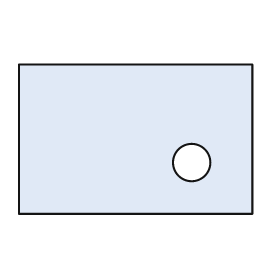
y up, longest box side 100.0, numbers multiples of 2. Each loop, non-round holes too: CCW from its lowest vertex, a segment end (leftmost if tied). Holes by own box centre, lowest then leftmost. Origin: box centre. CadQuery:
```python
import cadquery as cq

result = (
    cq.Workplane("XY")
    .moveTo(-50.0, -32.0)
    .lineTo(50.0, -32.0)
    .lineTo(50.0, 32.0)
    .lineTo(-50.0, 32.0)
    .close()
    .moveTo(24.0, -10.0)
    .circle(8.0)
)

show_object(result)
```